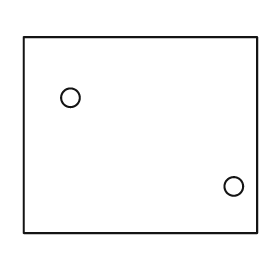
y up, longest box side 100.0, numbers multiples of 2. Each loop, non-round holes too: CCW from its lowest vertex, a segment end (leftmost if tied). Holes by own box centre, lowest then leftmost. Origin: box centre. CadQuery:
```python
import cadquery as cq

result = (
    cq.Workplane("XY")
    .moveTo(-50.0, -42.0)
    .lineTo(50.0, -42.0)
    .lineTo(50.0, 42.0)
    .lineTo(-50.0, 42.0)
    .close()
    .moveTo(40.0, -22.0)
    .circle(4.0)
    .moveTo(-30.0, 16.0)
    .circle(4.0)
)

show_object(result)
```